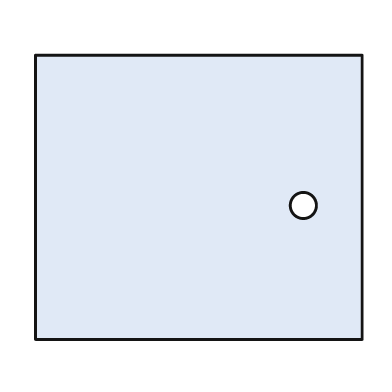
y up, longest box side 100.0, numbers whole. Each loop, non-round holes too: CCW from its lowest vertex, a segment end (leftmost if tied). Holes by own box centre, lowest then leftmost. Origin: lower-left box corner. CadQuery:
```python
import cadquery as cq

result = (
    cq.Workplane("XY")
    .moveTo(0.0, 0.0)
    .lineTo(100.0, 0.0)
    .lineTo(100.0, 87.0)
    .lineTo(0.0, 87.0)
    .close()
    .moveTo(82.0, 41.0)
    .circle(4.0)
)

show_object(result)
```